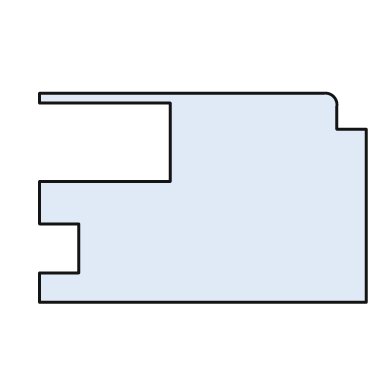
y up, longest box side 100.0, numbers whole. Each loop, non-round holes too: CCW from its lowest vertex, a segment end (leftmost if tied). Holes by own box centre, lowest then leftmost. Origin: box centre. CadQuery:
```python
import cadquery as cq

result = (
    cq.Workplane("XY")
    .moveTo(-50.0, -32.0)
    .lineTo(50.0, -32.0)
    .lineTo(50.0, 21.0)
    .lineTo(41.0, 21.0)
    .lineTo(41.0, 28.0)
    .threePointArc((40.0, 31.0), (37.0, 32.0))
    .lineTo(-50.0, 32.0)
    .lineTo(-50.0, 29.0)
    .lineTo(-10.0, 29.0)
    .lineTo(-10.0, 5.0)
    .lineTo(-50.0, 5.0)
    .lineTo(-50.0, -8.0)
    .lineTo(-38.0, -8.0)
    .lineTo(-38.0, -23.0)
    .lineTo(-50.0, -23.0)
    .close()
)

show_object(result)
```